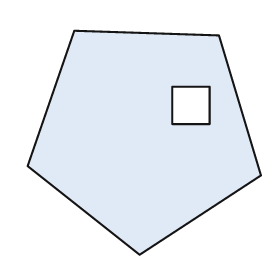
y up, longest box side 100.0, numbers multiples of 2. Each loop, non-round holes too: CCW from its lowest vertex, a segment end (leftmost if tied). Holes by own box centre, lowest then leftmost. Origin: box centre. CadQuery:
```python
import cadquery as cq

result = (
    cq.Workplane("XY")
    .moveTo(-2.0, -48.0)
    .lineTo(50.0, -14.0)
    .lineTo(32.0, 46.0)
    .lineTo(-30.0, 48.0)
    .lineTo(-50.0, -10.0)
    .close()
    .moveTo(12.0, 8.0)
    .lineTo(28.0, 8.0)
    .lineTo(28.0, 24.0)
    .lineTo(12.0, 24.0)
    .close()
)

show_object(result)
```